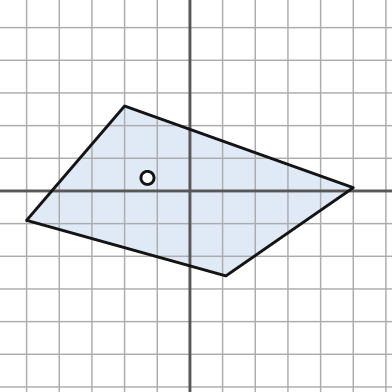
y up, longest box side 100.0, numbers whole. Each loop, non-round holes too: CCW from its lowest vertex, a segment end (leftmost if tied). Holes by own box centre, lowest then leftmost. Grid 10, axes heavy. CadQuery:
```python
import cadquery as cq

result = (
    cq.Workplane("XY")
    .moveTo(11.0, -26.0)
    .lineTo(50.0, 1.0)
    .lineTo(-20.0, 26.0)
    .lineTo(-50.0, -9.0)
    .close()
    .moveTo(-13.0, 4.0)
    .circle(2.0)
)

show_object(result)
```